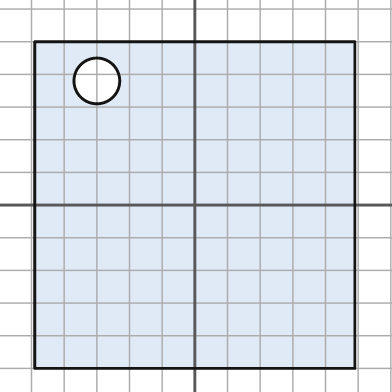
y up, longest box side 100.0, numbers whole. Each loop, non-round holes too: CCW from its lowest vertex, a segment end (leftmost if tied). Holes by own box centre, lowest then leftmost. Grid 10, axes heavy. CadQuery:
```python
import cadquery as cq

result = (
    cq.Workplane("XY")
    .moveTo(-49.0, -50.0)
    .lineTo(49.0, -50.0)
    .lineTo(49.0, 50.0)
    .lineTo(-49.0, 50.0)
    .close()
    .moveTo(-30.0, 38.0)
    .circle(7.0)
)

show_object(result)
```